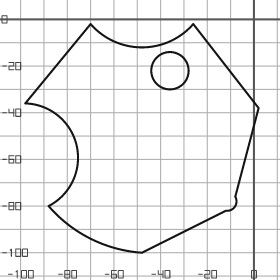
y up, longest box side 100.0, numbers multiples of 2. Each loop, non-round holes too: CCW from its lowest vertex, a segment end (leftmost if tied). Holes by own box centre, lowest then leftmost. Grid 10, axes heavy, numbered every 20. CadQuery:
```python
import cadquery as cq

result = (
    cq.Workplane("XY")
    .moveTo(-48.0, -100.0)
    .lineTo(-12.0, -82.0)
    .threePointArc((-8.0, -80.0), (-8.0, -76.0))
    .lineTo(2.0, -38.0)
    .lineTo(-26.0, -2.0)
    .threePointArc((-48.0, -12.0), (-70.0, -2.0))
    .lineTo(-98.0, -36.0)
    .threePointArc((-76.0, -54.0), (-88.0, -80.0))
    .threePointArc((-70.0, -94.0), (-48.0, -100.0))
    .close()
    .moveTo(-36.0, -22.0)
    .circle(8.0)
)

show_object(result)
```